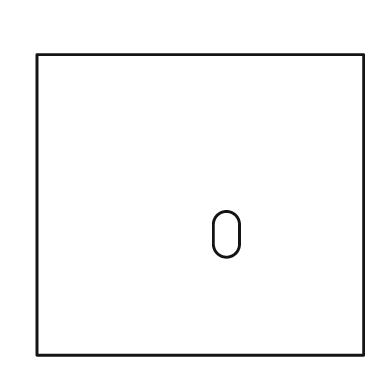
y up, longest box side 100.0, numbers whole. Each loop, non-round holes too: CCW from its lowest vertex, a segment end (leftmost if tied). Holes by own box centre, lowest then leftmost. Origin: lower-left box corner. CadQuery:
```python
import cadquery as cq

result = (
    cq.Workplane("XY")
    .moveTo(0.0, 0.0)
    .lineTo(100.0, 0.0)
    .lineTo(100.0, 92.0)
    .lineTo(0.0, 92.0)
    .close()
    .moveTo(54.0, 34.0)
    .threePointArc((58.0, 30.0), (62.0, 34.0))
    .lineTo(62.0, 40.0)
    .threePointArc((58.0, 44.0), (54.0, 40.0))
    .close()
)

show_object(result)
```